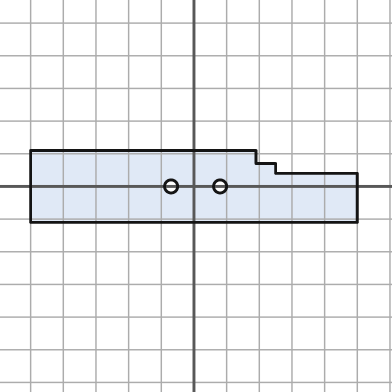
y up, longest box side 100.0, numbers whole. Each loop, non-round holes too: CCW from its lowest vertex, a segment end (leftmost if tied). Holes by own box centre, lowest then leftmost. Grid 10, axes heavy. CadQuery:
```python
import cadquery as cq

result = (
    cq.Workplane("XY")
    .moveTo(-50.0, -11.0)
    .lineTo(50.0, -11.0)
    .lineTo(50.0, 4.0)
    .lineTo(25.0, 4.0)
    .lineTo(25.0, 7.0)
    .lineTo(19.0, 7.0)
    .lineTo(19.0, 11.0)
    .lineTo(-50.0, 11.0)
    .close()
    .moveTo(-7.0, 0.0)
    .circle(2.0)
    .moveTo(8.0, 0.0)
    .circle(2.0)
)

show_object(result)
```